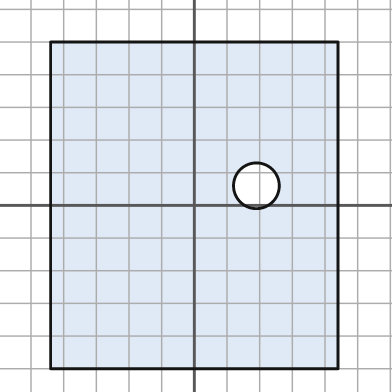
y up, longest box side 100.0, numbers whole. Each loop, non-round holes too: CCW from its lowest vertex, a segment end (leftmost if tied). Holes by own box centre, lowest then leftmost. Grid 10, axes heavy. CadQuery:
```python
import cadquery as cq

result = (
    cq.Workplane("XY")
    .moveTo(-44.0, -50.0)
    .lineTo(44.0, -50.0)
    .lineTo(44.0, 50.0)
    .lineTo(-44.0, 50.0)
    .close()
    .moveTo(19.0, 6.0)
    .circle(7.0)
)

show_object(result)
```